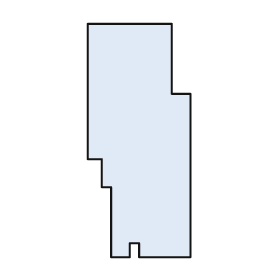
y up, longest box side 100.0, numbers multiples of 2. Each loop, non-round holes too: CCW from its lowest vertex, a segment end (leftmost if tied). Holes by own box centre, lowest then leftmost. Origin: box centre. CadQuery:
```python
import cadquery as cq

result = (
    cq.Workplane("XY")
    .moveTo(-12.0, -50.0)
    .lineTo(-4.0, -50.0)
    .lineTo(-4.0, -44.0)
    .lineTo(0.0, -44.0)
    .lineTo(0.0, -50.0)
    .lineTo(22.0, -50.0)
    .lineTo(22.0, 20.0)
    .lineTo(14.0, 20.0)
    .lineTo(14.0, 50.0)
    .lineTo(-22.0, 50.0)
    .lineTo(-22.0, -8.0)
    .lineTo(-16.0, -8.0)
    .lineTo(-16.0, -20.0)
    .lineTo(-12.0, -20.0)
    .close()
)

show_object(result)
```